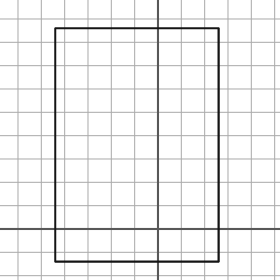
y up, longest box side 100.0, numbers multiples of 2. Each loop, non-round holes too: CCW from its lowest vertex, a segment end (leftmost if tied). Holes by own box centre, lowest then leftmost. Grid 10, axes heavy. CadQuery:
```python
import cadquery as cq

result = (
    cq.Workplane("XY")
    .moveTo(-44.0, -14.0)
    .lineTo(26.0, -14.0)
    .lineTo(26.0, 86.0)
    .lineTo(-44.0, 86.0)
    .close()
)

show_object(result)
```